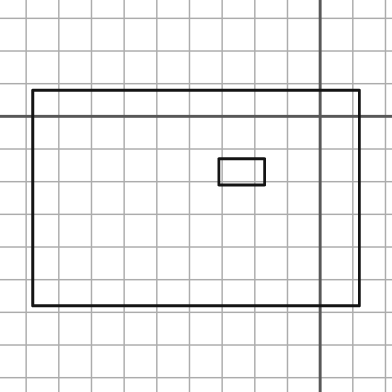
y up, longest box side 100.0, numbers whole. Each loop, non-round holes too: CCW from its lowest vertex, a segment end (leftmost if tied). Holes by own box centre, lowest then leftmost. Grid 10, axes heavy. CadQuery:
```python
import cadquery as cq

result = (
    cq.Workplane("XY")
    .moveTo(-88.0, -58.0)
    .lineTo(12.0, -58.0)
    .lineTo(12.0, 8.0)
    .lineTo(-88.0, 8.0)
    .close()
    .moveTo(-31.0, -21.0)
    .lineTo(-17.0, -21.0)
    .lineTo(-17.0, -13.0)
    .lineTo(-31.0, -13.0)
    .close()
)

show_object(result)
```